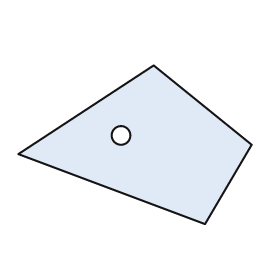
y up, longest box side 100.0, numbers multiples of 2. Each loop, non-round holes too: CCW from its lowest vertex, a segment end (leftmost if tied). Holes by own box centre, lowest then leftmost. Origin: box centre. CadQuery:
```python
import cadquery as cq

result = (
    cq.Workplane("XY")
    .moveTo(30.0, -34.0)
    .lineTo(50.0, 0.0)
    .lineTo(8.0, 34.0)
    .lineTo(-50.0, -4.0)
    .close()
    .moveTo(-6.0, 4.0)
    .circle(4.0)
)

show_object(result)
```